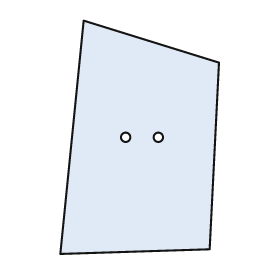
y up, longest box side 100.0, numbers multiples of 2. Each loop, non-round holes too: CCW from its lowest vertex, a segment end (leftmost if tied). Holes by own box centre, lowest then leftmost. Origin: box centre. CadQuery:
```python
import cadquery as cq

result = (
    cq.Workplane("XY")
    .moveTo(-34.0, -50.0)
    .lineTo(30.0, -48.0)
    .lineTo(34.0, 32.0)
    .lineTo(-24.0, 50.0)
    .close()
    .moveTo(-6.0, 0.0)
    .circle(2.0)
    .moveTo(8.0, 0.0)
    .circle(2.0)
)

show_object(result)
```